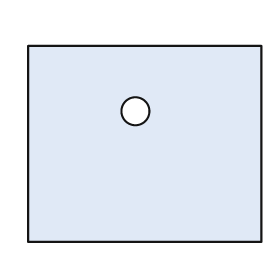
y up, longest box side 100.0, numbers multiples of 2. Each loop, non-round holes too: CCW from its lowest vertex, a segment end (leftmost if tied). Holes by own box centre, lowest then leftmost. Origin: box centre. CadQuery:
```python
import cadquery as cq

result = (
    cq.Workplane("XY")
    .moveTo(-50.0, -42.0)
    .lineTo(50.0, -42.0)
    .lineTo(50.0, 42.0)
    .lineTo(-50.0, 42.0)
    .close()
    .moveTo(-4.0, 14.0)
    .circle(6.0)
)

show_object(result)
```